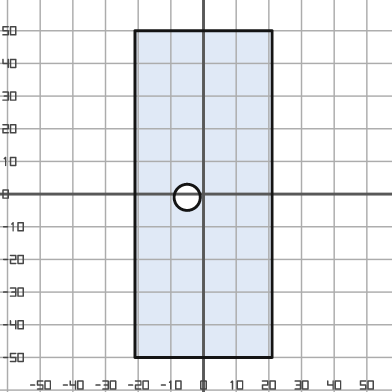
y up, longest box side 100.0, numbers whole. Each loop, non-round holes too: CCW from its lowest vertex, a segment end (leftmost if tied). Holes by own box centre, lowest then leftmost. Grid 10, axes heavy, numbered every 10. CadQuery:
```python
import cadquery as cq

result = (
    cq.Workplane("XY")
    .moveTo(-21.0, -50.0)
    .lineTo(21.0, -50.0)
    .lineTo(21.0, 50.0)
    .lineTo(-21.0, 50.0)
    .close()
    .moveTo(-5.0, -1.0)
    .circle(4.0)
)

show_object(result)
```